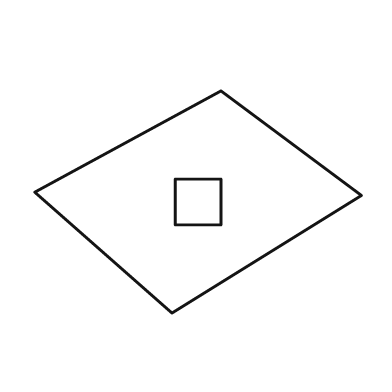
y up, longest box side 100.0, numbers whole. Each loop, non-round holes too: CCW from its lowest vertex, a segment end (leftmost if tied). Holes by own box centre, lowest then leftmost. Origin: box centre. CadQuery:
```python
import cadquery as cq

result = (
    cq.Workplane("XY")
    .moveTo(-8.0, -34.0)
    .lineTo(50.0, 2.0)
    .lineTo(7.0, 34.0)
    .lineTo(-50.0, 3.0)
    .close()
    .moveTo(-7.0, -7.0)
    .lineTo(7.0, -7.0)
    .lineTo(7.0, 7.0)
    .lineTo(-7.0, 7.0)
    .close()
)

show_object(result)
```